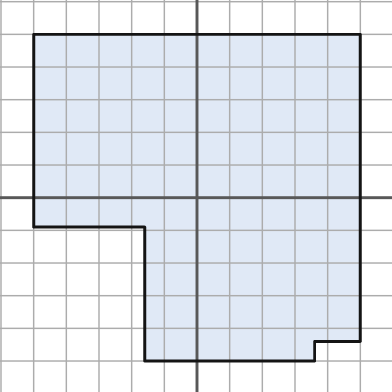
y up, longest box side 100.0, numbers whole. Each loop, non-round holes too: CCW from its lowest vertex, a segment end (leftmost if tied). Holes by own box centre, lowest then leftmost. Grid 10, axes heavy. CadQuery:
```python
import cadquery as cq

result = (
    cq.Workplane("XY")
    .moveTo(-16.0, -50.0)
    .lineTo(36.0, -50.0)
    .lineTo(36.0, -44.0)
    .lineTo(50.0, -44.0)
    .lineTo(50.0, 50.0)
    .lineTo(-50.0, 50.0)
    .lineTo(-50.0, -9.0)
    .lineTo(-16.0, -9.0)
    .close()
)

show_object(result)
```